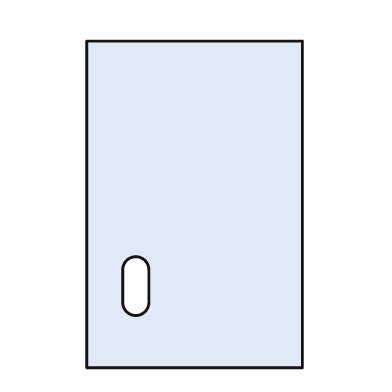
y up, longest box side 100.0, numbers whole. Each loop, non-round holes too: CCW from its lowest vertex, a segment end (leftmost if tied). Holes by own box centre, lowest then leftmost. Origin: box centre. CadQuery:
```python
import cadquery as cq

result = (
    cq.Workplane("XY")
    .moveTo(-33.0, -50.0)
    .lineTo(33.0, -50.0)
    .lineTo(33.0, 50.0)
    .lineTo(-33.0, 50.0)
    .close()
    .moveTo(-22.0, -30.0)
    .threePointArc((-18.0, -34.0), (-14.0, -30.0))
    .lineTo(-14.0, -20.0)
    .threePointArc((-18.0, -16.0), (-22.0, -20.0))
    .close()
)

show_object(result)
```